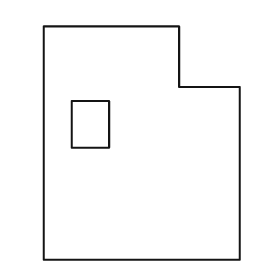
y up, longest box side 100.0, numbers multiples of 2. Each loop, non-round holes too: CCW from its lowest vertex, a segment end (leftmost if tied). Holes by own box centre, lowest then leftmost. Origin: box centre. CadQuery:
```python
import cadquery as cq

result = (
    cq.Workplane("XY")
    .moveTo(-42.0, -50.0)
    .lineTo(42.0, -50.0)
    .lineTo(42.0, 24.0)
    .lineTo(16.0, 24.0)
    .lineTo(16.0, 50.0)
    .lineTo(-42.0, 50.0)
    .close()
    .moveTo(-30.0, -2.0)
    .lineTo(-14.0, -2.0)
    .lineTo(-14.0, 18.0)
    .lineTo(-30.0, 18.0)
    .close()
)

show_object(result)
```